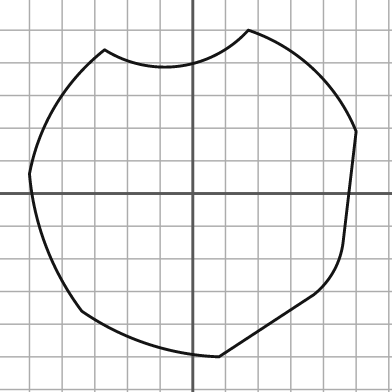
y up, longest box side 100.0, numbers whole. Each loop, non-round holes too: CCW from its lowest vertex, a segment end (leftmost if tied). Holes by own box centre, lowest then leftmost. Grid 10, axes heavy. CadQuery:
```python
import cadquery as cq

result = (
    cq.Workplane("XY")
    .moveTo(8.0, -50.0)
    .lineTo(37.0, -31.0)
    .threePointArc((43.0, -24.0), (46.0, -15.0))
    .lineTo(50.0, 19.0)
    .threePointArc((37.0, 38.0), (17.0, 50.0))
    .threePointArc((-4.0, 39.0), (-27.0, 44.0))
    .threePointArc((-42.0, 27.0), (-50.0, 6.0))
    .threePointArc((-45.0, -16.0), (-34.0, -36.0))
    .threePointArc((-14.0, -46.0), (8.0, -50.0))
    .close()
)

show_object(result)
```